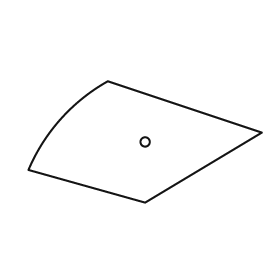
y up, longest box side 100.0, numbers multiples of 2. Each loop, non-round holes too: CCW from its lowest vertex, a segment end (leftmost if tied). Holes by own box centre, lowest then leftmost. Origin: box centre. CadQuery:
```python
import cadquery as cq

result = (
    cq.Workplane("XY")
    .moveTo(0.0, -26.0)
    .lineTo(50.0, 4.0)
    .lineTo(-16.0, 26.0)
    .threePointArc((-36.0, 10.0), (-50.0, -12.0))
    .close()
    .moveTo(0.0, 0.0)
    .circle(2.0)
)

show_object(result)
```